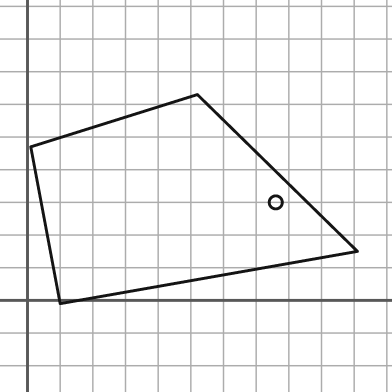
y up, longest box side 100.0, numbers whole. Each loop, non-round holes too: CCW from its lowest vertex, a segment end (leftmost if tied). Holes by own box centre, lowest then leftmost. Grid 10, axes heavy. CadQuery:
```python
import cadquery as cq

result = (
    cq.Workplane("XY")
    .moveTo(10.0, -1.0)
    .lineTo(101.0, 15.0)
    .lineTo(52.0, 63.0)
    .lineTo(1.0, 47.0)
    .close()
    .moveTo(76.0, 30.0)
    .circle(2.0)
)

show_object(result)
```